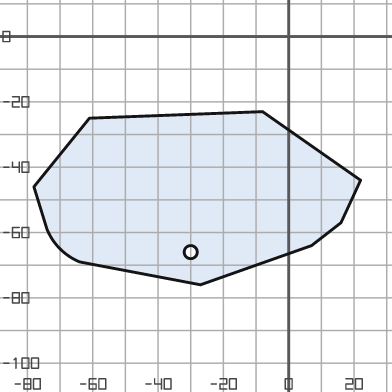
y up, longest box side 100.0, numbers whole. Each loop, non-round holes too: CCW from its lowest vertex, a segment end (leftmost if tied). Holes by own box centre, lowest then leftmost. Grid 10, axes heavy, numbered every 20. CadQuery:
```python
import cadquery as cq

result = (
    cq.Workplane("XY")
    .moveTo(-27.0, -76.0)
    .lineTo(7.0, -64.0)
    .lineTo(16.0, -57.0)
    .lineTo(22.0, -44.0)
    .lineTo(-8.0, -23.0)
    .lineTo(-61.0, -25.0)
    .lineTo(-78.0, -46.0)
    .lineTo(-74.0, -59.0)
    .threePointArc((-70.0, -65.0), (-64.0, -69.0))
    .close()
    .moveTo(-30.0, -66.0)
    .circle(2.0)
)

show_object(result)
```